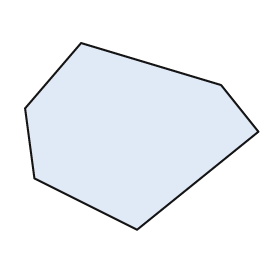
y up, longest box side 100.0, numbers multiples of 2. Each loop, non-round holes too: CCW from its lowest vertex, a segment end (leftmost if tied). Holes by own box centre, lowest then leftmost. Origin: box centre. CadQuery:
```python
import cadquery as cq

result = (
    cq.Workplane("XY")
    .moveTo(-2.0, -40.0)
    .lineTo(50.0, 2.0)
    .lineTo(34.0, 22.0)
    .lineTo(-26.0, 40.0)
    .lineTo(-50.0, 12.0)
    .lineTo(-46.0, -18.0)
    .close()
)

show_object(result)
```